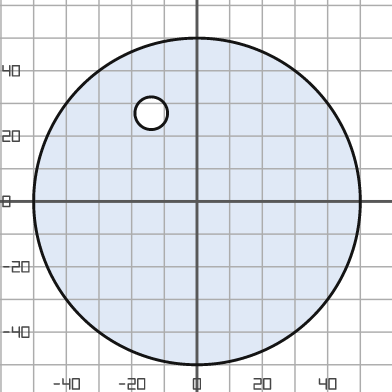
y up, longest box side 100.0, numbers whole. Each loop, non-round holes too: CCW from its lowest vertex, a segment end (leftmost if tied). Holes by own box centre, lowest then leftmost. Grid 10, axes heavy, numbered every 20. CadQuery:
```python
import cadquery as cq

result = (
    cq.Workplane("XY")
    .moveTo(0.0, 0.0)
    .circle(50.0)
    .moveTo(-14.0, 27.0)
    .circle(5.0)
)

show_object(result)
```